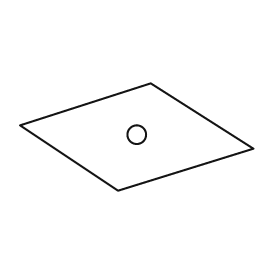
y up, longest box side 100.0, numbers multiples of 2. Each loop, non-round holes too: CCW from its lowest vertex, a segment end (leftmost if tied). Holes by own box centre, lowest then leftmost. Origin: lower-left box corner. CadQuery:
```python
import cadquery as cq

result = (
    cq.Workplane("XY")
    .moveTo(42.0, 0.0)
    .lineTo(100.0, 18.0)
    .lineTo(56.0, 46.0)
    .lineTo(0.0, 28.0)
    .close()
    .moveTo(50.0, 24.0)
    .circle(4.0)
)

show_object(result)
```